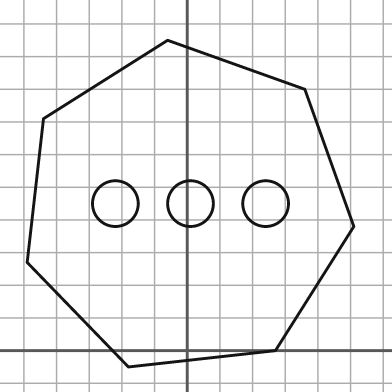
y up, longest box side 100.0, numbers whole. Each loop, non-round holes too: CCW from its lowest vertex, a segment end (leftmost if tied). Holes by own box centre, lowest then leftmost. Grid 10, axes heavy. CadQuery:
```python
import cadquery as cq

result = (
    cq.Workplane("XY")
    .moveTo(-18.0, -5.0)
    .lineTo(27.0, 0.0)
    .lineTo(51.0, 38.0)
    .lineTo(36.0, 80.0)
    .lineTo(-6.0, 95.0)
    .lineTo(-44.0, 71.0)
    .lineTo(-49.0, 27.0)
    .close()
    .moveTo(-22.0, 45.0)
    .circle(7.0)
    .moveTo(1.0, 45.0)
    .circle(7.0)
    .moveTo(24.0, 45.0)
    .circle(7.0)
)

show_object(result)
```